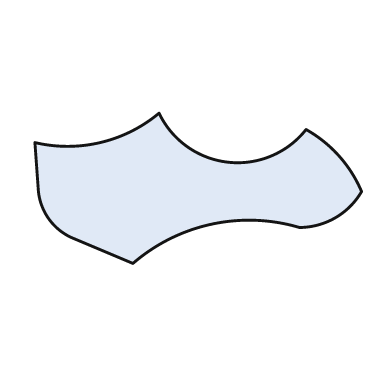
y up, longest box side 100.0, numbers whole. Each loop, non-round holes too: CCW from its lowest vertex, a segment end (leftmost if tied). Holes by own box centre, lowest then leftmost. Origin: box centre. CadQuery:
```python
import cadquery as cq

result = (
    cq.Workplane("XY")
    .moveTo(-20.0, -23.0)
    .threePointArc((4.0, -11.0), (31.0, -12.0))
    .threePointArc((42.0, -9.0), (50.0, -1.0))
    .threePointArc((43.0, 10.0), (33.0, 18.0))
    .threePointArc((9.0, 8.0), (-12.0, 23.0))
    .threePointArc((-30.0, 14.0), (-50.0, 14.0))
    .lineTo(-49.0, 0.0)
    .threePointArc((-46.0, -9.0), (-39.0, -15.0))
    .close()
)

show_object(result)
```